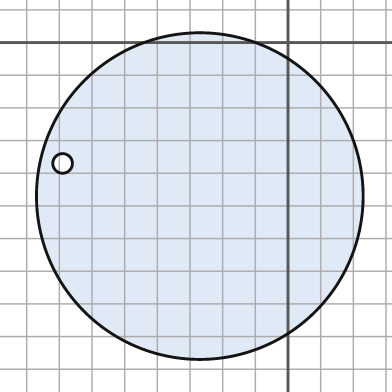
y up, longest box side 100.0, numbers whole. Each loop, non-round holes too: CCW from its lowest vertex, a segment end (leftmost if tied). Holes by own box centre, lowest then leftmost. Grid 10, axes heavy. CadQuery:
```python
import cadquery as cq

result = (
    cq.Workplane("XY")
    .moveTo(-27.0, -47.0)
    .circle(50.0)
    .moveTo(-69.0, -37.0)
    .circle(3.0)
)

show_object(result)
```